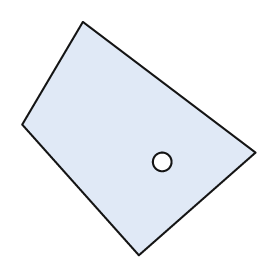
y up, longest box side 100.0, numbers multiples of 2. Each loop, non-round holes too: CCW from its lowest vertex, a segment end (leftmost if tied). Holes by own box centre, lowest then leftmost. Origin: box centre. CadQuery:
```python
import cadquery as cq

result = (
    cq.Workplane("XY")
    .moveTo(0.0, -50.0)
    .lineTo(50.0, -6.0)
    .lineTo(-24.0, 50.0)
    .lineTo(-50.0, 6.0)
    .close()
    .moveTo(10.0, -10.0)
    .circle(4.0)
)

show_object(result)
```